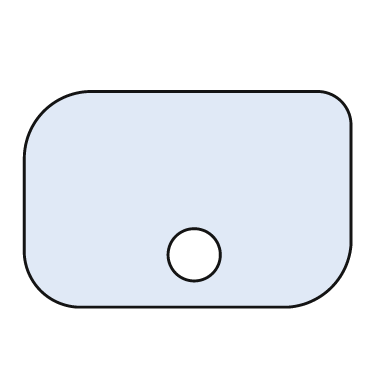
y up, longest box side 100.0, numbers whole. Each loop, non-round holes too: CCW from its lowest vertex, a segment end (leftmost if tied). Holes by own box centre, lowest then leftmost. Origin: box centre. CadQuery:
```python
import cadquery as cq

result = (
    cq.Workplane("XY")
    .moveTo(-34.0, -33.0)
    .lineTo(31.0, -33.0)
    .threePointArc((44.0, -27.0), (50.0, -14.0))
    .lineTo(50.0, 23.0)
    .threePointArc((47.0, 30.0), (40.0, 33.0))
    .lineTo(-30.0, 33.0)
    .threePointArc((-44.0, 27.0), (-50.0, 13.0))
    .lineTo(-50.0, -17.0)
    .threePointArc((-45.0, -28.0), (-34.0, -33.0))
    .close()
    .moveTo(2.0, -17.0)
    .circle(8.0)
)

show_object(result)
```